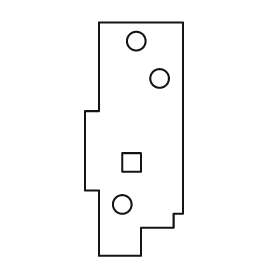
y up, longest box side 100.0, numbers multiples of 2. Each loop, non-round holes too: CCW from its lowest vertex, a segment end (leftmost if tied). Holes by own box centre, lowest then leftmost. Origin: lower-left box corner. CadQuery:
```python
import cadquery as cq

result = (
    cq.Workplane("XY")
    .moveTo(6.0, 0.0)
    .lineTo(24.0, 0.0)
    .lineTo(24.0, 12.0)
    .lineTo(38.0, 12.0)
    .lineTo(38.0, 18.0)
    .lineTo(42.0, 18.0)
    .lineTo(42.0, 100.0)
    .lineTo(6.0, 100.0)
    .lineTo(6.0, 62.0)
    .lineTo(0.0, 62.0)
    .lineTo(0.0, 28.0)
    .lineTo(6.0, 28.0)
    .close()
    .moveTo(16.0, 22.0)
    .circle(4.0)
    .moveTo(16.0, 36.0)
    .lineTo(24.0, 36.0)
    .lineTo(24.0, 44.0)
    .lineTo(16.0, 44.0)
    .close()
    .moveTo(32.0, 76.0)
    .circle(4.0)
    .moveTo(22.0, 92.0)
    .circle(4.0)
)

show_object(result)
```